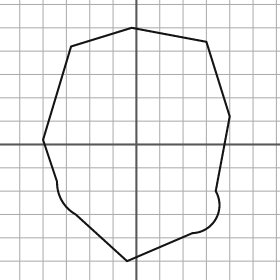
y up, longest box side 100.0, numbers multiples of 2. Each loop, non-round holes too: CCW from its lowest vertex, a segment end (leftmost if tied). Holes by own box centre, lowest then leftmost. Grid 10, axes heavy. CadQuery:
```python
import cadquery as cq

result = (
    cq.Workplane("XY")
    .moveTo(-4.0, -50.0)
    .lineTo(24.0, -38.0)
    .threePointArc((34.0, -32.0), (34.0, -20.0))
    .lineTo(40.0, 12.0)
    .lineTo(30.0, 44.0)
    .lineTo(-2.0, 50.0)
    .lineTo(-28.0, 42.0)
    .lineTo(-40.0, 2.0)
    .lineTo(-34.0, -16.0)
    .threePointArc((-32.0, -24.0), (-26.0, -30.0))
    .close()
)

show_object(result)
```